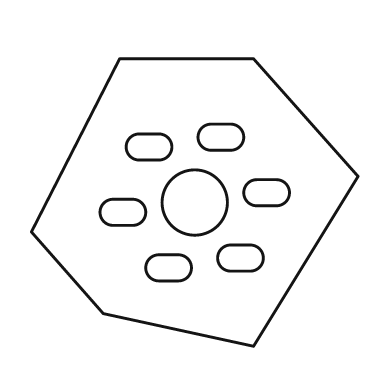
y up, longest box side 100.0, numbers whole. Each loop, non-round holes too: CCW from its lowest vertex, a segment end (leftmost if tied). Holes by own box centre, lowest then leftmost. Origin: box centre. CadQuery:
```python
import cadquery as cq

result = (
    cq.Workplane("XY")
    .moveTo(18.0, -44.0)
    .lineTo(50.0, 8.0)
    .lineTo(18.0, 44.0)
    .lineTo(-23.0, 44.0)
    .lineTo(-50.0, -9.0)
    .lineTo(-28.0, -34.0)
    .close()
    .moveTo(-11.0, -24.0)
    .lineTo(-5.0, -24.0)
    .threePointArc((-1.0, -20.0), (-5.0, -16.0))
    .lineTo(-11.0, -16.0)
    .threePointArc((-15.0, -20.0), (-11.0, -24.0))
    .close()
    .moveTo(11.0, -21.0)
    .lineTo(17.0, -21.0)
    .threePointArc((21.0, -17.0), (17.0, -13.0))
    .lineTo(11.0, -13.0)
    .threePointArc((7.0, -17.0), (11.0, -21.0))
    .close()
    .moveTo(-25.0, -7.0)
    .lineTo(-19.0, -7.0)
    .threePointArc((-15.0, -3.0), (-19.0, 1.0))
    .lineTo(-25.0, 1.0)
    .threePointArc((-29.0, -3.0), (-25.0, -7.0))
    .close()
    .moveTo(0.0, 0.0)
    .circle(10.0)
    .moveTo(19.0, -1.0)
    .lineTo(25.0, -1.0)
    .threePointArc((29.0, 3.0), (25.0, 7.0))
    .lineTo(19.0, 7.0)
    .threePointArc((15.0, 3.0), (19.0, -1.0))
    .close()
    .moveTo(-17.0, 13.0)
    .lineTo(-11.0, 13.0)
    .threePointArc((-7.0, 17.0), (-11.0, 21.0))
    .lineTo(-17.0, 21.0)
    .threePointArc((-21.0, 17.0), (-17.0, 13.0))
    .close()
    .moveTo(5.0, 16.0)
    .lineTo(11.0, 16.0)
    .threePointArc((15.0, 20.0), (11.0, 24.0))
    .lineTo(5.0, 24.0)
    .threePointArc((1.0, 20.0), (5.0, 16.0))
    .close()
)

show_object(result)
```